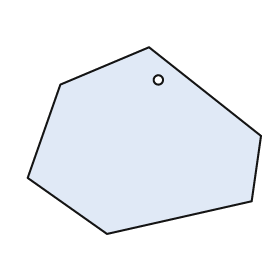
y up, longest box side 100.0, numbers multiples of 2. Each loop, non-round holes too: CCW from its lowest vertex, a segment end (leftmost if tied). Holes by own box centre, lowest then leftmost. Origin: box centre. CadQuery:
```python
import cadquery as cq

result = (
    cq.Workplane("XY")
    .moveTo(-16.0, -40.0)
    .lineTo(46.0, -26.0)
    .lineTo(50.0, 2.0)
    .lineTo(2.0, 40.0)
    .lineTo(-36.0, 24.0)
    .lineTo(-50.0, -16.0)
    .close()
    .moveTo(6.0, 26.0)
    .circle(2.0)
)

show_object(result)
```